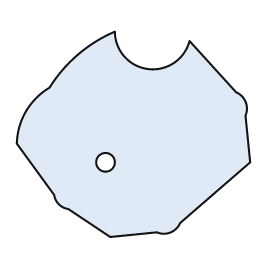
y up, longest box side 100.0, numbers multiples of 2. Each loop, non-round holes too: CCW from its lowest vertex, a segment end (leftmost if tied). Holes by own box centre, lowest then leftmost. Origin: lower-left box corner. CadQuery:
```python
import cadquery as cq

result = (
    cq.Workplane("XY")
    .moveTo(40.0, 0.0)
    .lineTo(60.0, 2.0)
    .threePointArc((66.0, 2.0), (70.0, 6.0))
    .lineTo(100.0, 32.0)
    .lineTo(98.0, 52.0)
    .threePointArc((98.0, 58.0), (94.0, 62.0))
    .lineTo(74.0, 84.0)
    .threePointArc((56.0, 72.0), (42.0, 88.0))
    .threePointArc((26.0, 78.0), (14.0, 64.0))
    .threePointArc((4.0, 54.0), (0.0, 40.0))
    .lineTo(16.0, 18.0)
    .threePointArc((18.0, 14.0), (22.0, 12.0))
    .close()
    .moveTo(38.0, 32.0)
    .circle(4.0)
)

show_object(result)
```